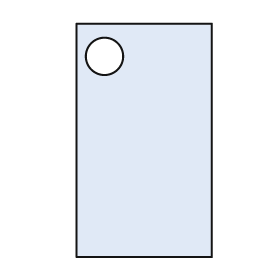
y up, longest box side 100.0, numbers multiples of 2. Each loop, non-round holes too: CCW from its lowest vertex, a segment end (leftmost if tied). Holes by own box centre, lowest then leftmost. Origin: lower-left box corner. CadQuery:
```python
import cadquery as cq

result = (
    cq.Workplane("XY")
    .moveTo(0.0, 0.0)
    .lineTo(58.0, 0.0)
    .lineTo(58.0, 100.0)
    .lineTo(0.0, 100.0)
    .close()
    .moveTo(12.0, 86.0)
    .circle(8.0)
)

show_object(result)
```